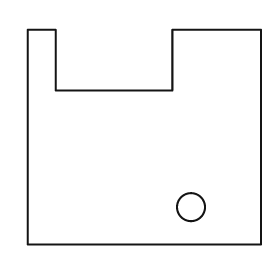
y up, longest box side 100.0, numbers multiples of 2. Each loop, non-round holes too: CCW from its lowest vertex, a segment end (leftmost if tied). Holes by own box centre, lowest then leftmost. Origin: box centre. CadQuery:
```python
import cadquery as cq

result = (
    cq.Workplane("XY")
    .moveTo(-50.0, -46.0)
    .lineTo(50.0, -46.0)
    .lineTo(50.0, 46.0)
    .lineTo(12.0, 46.0)
    .lineTo(12.0, 20.0)
    .lineTo(-38.0, 20.0)
    .lineTo(-38.0, 46.0)
    .lineTo(-50.0, 46.0)
    .close()
    .moveTo(20.0, -30.0)
    .circle(6.0)
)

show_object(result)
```